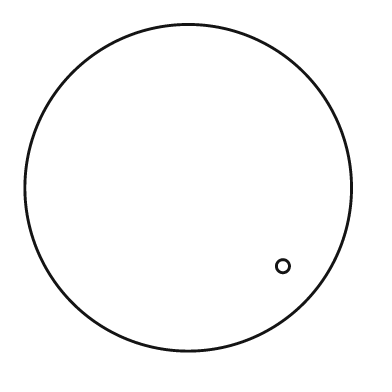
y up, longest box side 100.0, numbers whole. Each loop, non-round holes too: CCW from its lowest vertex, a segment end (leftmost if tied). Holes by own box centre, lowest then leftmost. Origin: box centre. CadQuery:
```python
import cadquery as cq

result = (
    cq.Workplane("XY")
    .moveTo(0.0, 0.0)
    .circle(50.0)
    .moveTo(29.0, -24.0)
    .circle(2.0)
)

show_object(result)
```